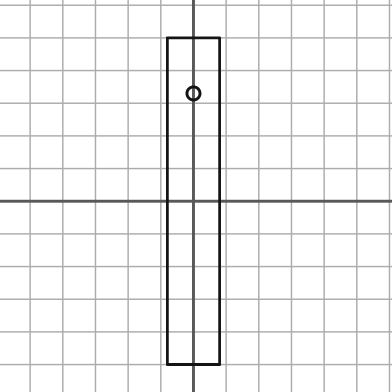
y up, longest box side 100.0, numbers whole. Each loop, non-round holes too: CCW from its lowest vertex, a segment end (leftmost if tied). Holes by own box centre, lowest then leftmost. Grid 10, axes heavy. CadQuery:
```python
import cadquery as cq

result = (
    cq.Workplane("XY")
    .moveTo(-8.0, -50.0)
    .lineTo(8.0, -50.0)
    .lineTo(8.0, 50.0)
    .lineTo(-8.0, 50.0)
    .close()
    .moveTo(0.0, 33.0)
    .circle(2.0)
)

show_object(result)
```